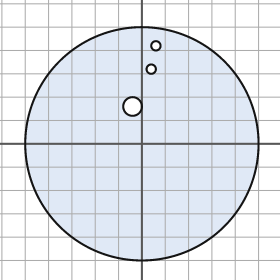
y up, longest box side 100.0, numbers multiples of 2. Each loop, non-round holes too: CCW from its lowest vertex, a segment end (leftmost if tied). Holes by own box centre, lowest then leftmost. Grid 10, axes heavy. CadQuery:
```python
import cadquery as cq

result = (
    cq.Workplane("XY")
    .moveTo(0.0, 0.0)
    .circle(50.0)
    .moveTo(-4.0, 16.0)
    .circle(4.0)
    .moveTo(4.0, 32.0)
    .circle(2.0)
    .moveTo(6.0, 42.0)
    .circle(2.0)
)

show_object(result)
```